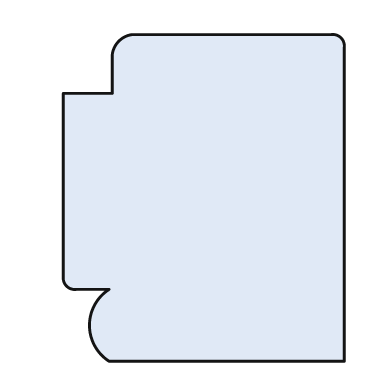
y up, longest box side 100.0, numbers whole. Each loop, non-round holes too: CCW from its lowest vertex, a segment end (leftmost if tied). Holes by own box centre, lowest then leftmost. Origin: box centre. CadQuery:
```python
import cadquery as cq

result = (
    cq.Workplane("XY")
    .moveTo(-29.0, -50.0)
    .lineTo(43.0, -50.0)
    .lineTo(43.0, 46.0)
    .threePointArc((42.0, 49.0), (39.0, 50.0))
    .lineTo(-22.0, 50.0)
    .threePointArc((-26.0, 48.0), (-28.0, 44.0))
    .lineTo(-28.0, 32.0)
    .lineTo(-43.0, 32.0)
    .lineTo(-43.0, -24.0)
    .threePointArc((-42.0, -27.0), (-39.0, -28.0))
    .lineTo(-29.0, -28.0)
    .threePointArc((-35.0, -39.0), (-29.0, -50.0))
    .close()
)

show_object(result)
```